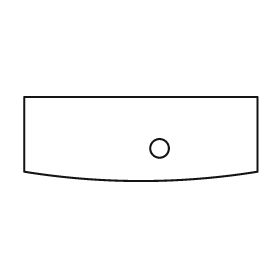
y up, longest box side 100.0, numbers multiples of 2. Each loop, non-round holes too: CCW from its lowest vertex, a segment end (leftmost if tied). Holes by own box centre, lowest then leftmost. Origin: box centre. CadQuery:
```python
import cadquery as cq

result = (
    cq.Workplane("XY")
    .moveTo(-50.0, -14.0)
    .threePointArc((0.0, -18.0), (50.0, -14.0))
    .lineTo(50.0, 18.0)
    .lineTo(-50.0, 18.0)
    .close()
    .moveTo(8.0, -4.0)
    .circle(4.0)
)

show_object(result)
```